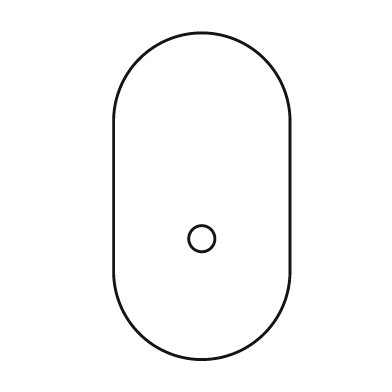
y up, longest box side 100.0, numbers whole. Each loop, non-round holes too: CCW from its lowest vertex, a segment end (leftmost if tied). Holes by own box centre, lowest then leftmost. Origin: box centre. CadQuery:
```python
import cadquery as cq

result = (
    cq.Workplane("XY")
    .moveTo(-27.0, -23.0)
    .threePointArc((0.0, -50.0), (27.0, -23.0))
    .lineTo(27.0, 23.0)
    .threePointArc((0.0, 50.0), (-27.0, 23.0))
    .close()
    .moveTo(0.0, -13.0)
    .circle(4.0)
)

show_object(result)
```